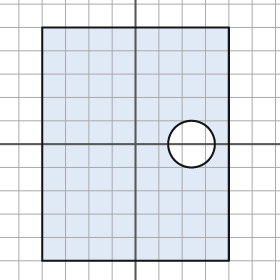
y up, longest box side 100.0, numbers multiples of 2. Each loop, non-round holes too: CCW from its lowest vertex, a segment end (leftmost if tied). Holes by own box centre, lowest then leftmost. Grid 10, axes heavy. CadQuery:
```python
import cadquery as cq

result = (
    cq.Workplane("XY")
    .moveTo(-40.0, -50.0)
    .lineTo(40.0, -50.0)
    .lineTo(40.0, 50.0)
    .lineTo(-40.0, 50.0)
    .close()
    .moveTo(24.0, 0.0)
    .circle(10.0)
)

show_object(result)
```